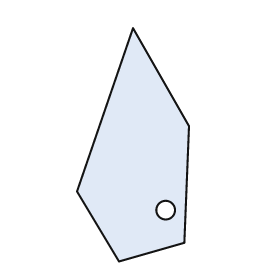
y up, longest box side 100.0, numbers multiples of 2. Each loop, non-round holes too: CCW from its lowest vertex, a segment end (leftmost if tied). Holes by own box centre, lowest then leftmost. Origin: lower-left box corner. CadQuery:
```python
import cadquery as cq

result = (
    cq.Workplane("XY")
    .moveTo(18.0, 0.0)
    .lineTo(46.0, 8.0)
    .lineTo(48.0, 58.0)
    .lineTo(24.0, 100.0)
    .lineTo(0.0, 30.0)
    .close()
    .moveTo(38.0, 22.0)
    .circle(4.0)
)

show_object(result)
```